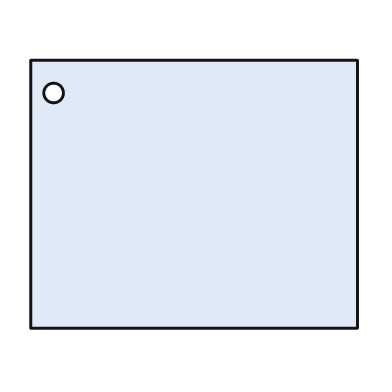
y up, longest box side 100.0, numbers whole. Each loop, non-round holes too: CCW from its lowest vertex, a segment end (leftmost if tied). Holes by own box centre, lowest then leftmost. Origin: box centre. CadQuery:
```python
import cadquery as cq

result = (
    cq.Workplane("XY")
    .moveTo(-50.0, -41.0)
    .lineTo(50.0, -41.0)
    .lineTo(50.0, 41.0)
    .lineTo(-50.0, 41.0)
    .close()
    .moveTo(-43.0, 31.0)
    .circle(3.0)
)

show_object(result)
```